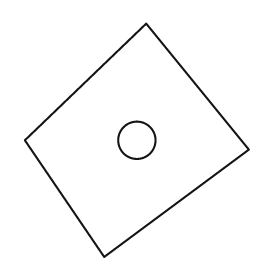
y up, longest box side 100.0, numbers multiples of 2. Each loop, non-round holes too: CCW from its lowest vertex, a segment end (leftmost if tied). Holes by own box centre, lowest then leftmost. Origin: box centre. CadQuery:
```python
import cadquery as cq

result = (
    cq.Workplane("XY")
    .moveTo(-14.0, -50.0)
    .lineTo(48.0, -4.0)
    .lineTo(4.0, 50.0)
    .lineTo(-48.0, 0.0)
    .close()
    .moveTo(0.0, 0.0)
    .circle(8.0)
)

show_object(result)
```